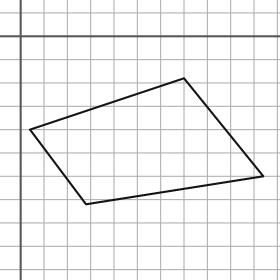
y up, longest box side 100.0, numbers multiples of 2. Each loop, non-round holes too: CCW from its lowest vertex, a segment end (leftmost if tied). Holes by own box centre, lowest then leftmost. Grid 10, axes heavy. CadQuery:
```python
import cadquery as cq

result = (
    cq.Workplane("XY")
    .moveTo(28.0, -72.0)
    .lineTo(104.0, -60.0)
    .lineTo(70.0, -18.0)
    .lineTo(4.0, -40.0)
    .close()
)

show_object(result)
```